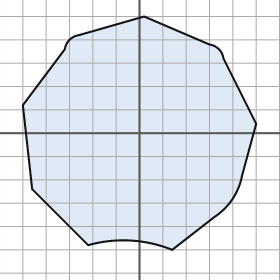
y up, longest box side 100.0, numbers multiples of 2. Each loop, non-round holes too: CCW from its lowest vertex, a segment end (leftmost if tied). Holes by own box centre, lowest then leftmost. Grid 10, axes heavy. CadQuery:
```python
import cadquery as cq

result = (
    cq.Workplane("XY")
    .moveTo(14.0, -50.0)
    .lineTo(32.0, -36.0)
    .threePointArc((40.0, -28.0), (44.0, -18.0))
    .lineTo(50.0, 4.0)
    .lineTo(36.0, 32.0)
    .threePointArc((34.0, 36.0), (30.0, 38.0))
    .lineTo(2.0, 50.0)
    .lineTo(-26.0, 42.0)
    .threePointArc((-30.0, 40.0), (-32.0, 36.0))
    .lineTo(-50.0, 12.0)
    .lineTo(-46.0, -24.0)
    .lineTo(-22.0, -48.0)
    .threePointArc((-4.0, -46.0), (14.0, -50.0))
    .close()
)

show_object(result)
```